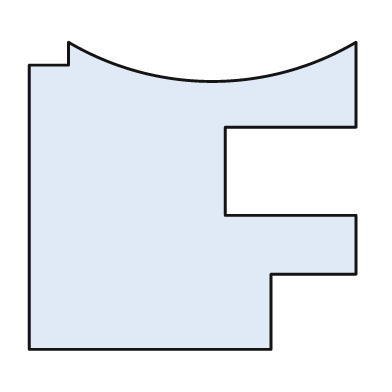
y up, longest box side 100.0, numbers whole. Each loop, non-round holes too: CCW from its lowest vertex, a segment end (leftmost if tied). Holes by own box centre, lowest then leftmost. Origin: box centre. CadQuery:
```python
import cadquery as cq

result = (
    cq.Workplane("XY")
    .moveTo(-50.0, -47.0)
    .lineTo(24.0, -47.0)
    .lineTo(24.0, -24.0)
    .lineTo(50.0, -24.0)
    .lineTo(50.0, -6.0)
    .lineTo(10.0, -6.0)
    .lineTo(10.0, 21.0)
    .lineTo(50.0, 21.0)
    .lineTo(50.0, 47.0)
    .threePointArc((6.0, 35.0), (-38.0, 47.0))
    .lineTo(-38.0, 40.0)
    .lineTo(-50.0, 40.0)
    .close()
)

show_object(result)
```